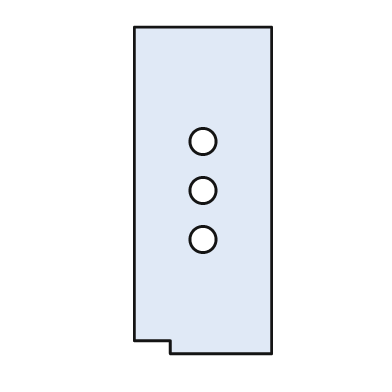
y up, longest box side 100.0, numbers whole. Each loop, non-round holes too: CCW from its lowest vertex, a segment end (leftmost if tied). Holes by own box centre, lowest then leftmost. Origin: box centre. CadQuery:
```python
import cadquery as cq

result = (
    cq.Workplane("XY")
    .moveTo(-10.0, -50.0)
    .lineTo(21.0, -50.0)
    .lineTo(21.0, 50.0)
    .lineTo(-21.0, 50.0)
    .lineTo(-21.0, -46.0)
    .lineTo(-10.0, -46.0)
    .close()
    .moveTo(0.0, -15.0)
    .circle(4.0)
    .moveTo(0.0, 0.0)
    .circle(4.0)
    .moveTo(0.0, 15.0)
    .circle(4.0)
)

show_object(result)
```